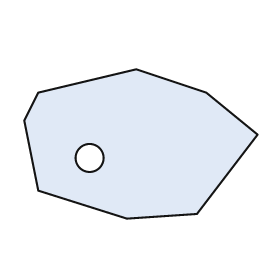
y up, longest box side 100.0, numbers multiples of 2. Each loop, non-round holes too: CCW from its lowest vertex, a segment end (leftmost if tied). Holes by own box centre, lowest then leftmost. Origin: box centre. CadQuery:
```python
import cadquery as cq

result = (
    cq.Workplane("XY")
    .moveTo(-6.0, -32.0)
    .lineTo(24.0, -30.0)
    .lineTo(50.0, 4.0)
    .lineTo(28.0, 22.0)
    .lineTo(-2.0, 32.0)
    .lineTo(-44.0, 22.0)
    .lineTo(-50.0, 10.0)
    .lineTo(-44.0, -20.0)
    .close()
    .moveTo(-22.0, -6.0)
    .circle(6.0)
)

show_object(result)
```